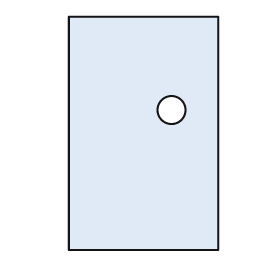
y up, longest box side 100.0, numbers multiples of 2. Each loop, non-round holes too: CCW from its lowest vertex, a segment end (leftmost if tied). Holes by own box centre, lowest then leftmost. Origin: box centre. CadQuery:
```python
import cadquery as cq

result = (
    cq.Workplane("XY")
    .moveTo(-32.0, -50.0)
    .lineTo(32.0, -50.0)
    .lineTo(32.0, 50.0)
    .lineTo(-32.0, 50.0)
    .close()
    .moveTo(12.0, 10.0)
    .circle(6.0)
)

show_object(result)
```